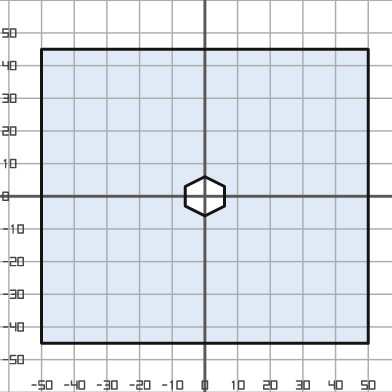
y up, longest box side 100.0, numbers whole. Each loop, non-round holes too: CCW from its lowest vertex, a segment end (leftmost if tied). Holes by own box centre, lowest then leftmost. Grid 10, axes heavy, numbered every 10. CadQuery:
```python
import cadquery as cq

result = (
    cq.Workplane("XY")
    .moveTo(-50.0, -45.0)
    .lineTo(50.0, -45.0)
    .lineTo(50.0, 45.0)
    .lineTo(-50.0, 45.0)
    .close()
    .moveTo(0.0, -6.0)
    .lineTo(6.0, -3.0)
    .lineTo(6.0, 3.0)
    .lineTo(0.0, 6.0)
    .lineTo(-6.0, 3.0)
    .lineTo(-6.0, -3.0)
    .close()
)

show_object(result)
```